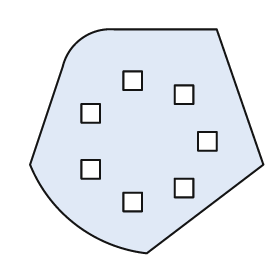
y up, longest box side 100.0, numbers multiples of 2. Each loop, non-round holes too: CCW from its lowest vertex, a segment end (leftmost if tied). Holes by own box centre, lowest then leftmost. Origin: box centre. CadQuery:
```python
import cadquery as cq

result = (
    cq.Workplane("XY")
    .moveTo(0.0, -48.0)
    .lineTo(50.0, -10.0)
    .lineTo(30.0, 48.0)
    .lineTo(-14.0, 48.0)
    .threePointArc((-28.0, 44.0), (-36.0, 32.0))
    .lineTo(-50.0, -10.0)
    .threePointArc((-30.0, -36.0), (0.0, -48.0))
    .close()
    .moveTo(-10.0, -30.0)
    .lineTo(-2.0, -30.0)
    .lineTo(-2.0, -22.0)
    .lineTo(-10.0, -22.0)
    .close()
    .moveTo(12.0, -24.0)
    .lineTo(20.0, -24.0)
    .lineTo(20.0, -16.0)
    .lineTo(12.0, -16.0)
    .close()
    .moveTo(-28.0, -16.0)
    .lineTo(-20.0, -16.0)
    .lineTo(-20.0, -8.0)
    .lineTo(-28.0, -8.0)
    .close()
    .moveTo(22.0, -4.0)
    .lineTo(30.0, -4.0)
    .lineTo(30.0, 4.0)
    .lineTo(22.0, 4.0)
    .close()
    .moveTo(-28.0, 8.0)
    .lineTo(-20.0, 8.0)
    .lineTo(-20.0, 16.0)
    .lineTo(-28.0, 16.0)
    .close()
    .moveTo(12.0, 16.0)
    .lineTo(20.0, 16.0)
    .lineTo(20.0, 24.0)
    .lineTo(12.0, 24.0)
    .close()
    .moveTo(-10.0, 22.0)
    .lineTo(-2.0, 22.0)
    .lineTo(-2.0, 30.0)
    .lineTo(-10.0, 30.0)
    .close()
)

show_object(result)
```